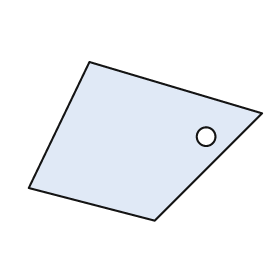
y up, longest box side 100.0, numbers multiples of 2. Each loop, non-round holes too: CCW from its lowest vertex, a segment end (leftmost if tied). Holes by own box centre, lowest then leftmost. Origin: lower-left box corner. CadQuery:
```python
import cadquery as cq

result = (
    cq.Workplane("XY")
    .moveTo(54.0, 0.0)
    .lineTo(100.0, 46.0)
    .lineTo(26.0, 68.0)
    .lineTo(0.0, 14.0)
    .close()
    .moveTo(76.0, 36.0)
    .circle(4.0)
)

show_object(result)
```